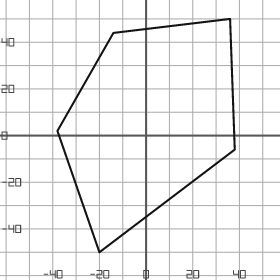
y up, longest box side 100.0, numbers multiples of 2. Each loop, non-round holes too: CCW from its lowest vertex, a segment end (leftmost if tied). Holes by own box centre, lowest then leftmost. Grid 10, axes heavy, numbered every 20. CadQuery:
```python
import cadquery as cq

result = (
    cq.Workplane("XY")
    .moveTo(-20.0, -50.0)
    .lineTo(38.0, -6.0)
    .lineTo(36.0, 50.0)
    .lineTo(-14.0, 44.0)
    .lineTo(-38.0, 2.0)
    .close()
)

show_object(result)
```